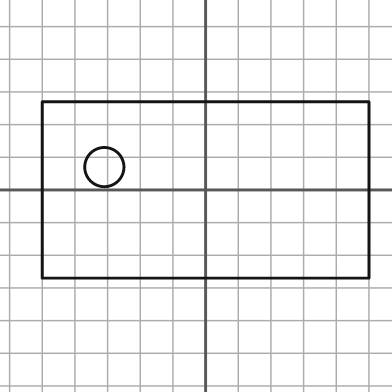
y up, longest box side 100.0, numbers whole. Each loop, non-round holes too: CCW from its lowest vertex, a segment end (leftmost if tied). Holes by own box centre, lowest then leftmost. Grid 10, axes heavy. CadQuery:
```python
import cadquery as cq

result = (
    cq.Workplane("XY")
    .moveTo(-50.0, -27.0)
    .lineTo(50.0, -27.0)
    .lineTo(50.0, 27.0)
    .lineTo(-50.0, 27.0)
    .close()
    .moveTo(-31.0, 7.0)
    .circle(6.0)
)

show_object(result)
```